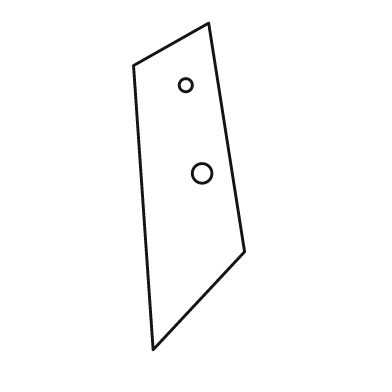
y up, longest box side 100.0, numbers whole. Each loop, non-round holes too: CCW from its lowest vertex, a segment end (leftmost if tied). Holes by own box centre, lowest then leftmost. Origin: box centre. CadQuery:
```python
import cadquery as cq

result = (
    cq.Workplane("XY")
    .moveTo(-11.0, -50.0)
    .lineTo(17.0, -20.0)
    .lineTo(6.0, 50.0)
    .lineTo(-17.0, 37.0)
    .close()
    .moveTo(4.0, 4.0)
    .circle(3.0)
    .moveTo(-1.0, 31.0)
    .circle(2.0)
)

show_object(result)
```